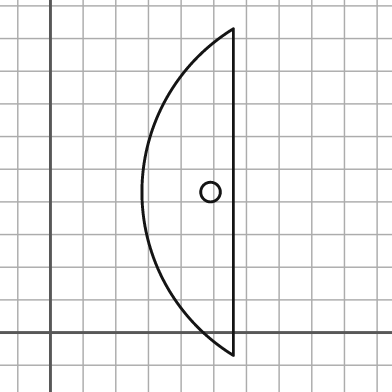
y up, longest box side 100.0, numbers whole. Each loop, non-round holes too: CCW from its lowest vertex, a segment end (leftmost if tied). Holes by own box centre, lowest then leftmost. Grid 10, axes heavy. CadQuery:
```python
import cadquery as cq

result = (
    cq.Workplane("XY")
    .moveTo(56.0, -7.0)
    .lineTo(56.0, 93.0)
    .threePointArc((28.0, 43.0), (56.0, -7.0))
    .close()
    .moveTo(49.0, 43.0)
    .circle(3.0)
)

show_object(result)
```